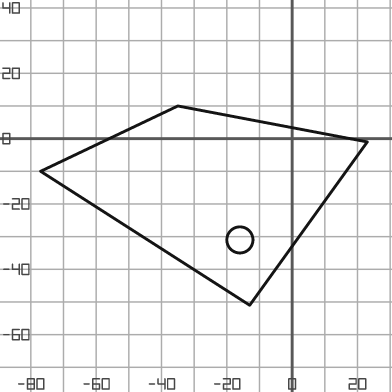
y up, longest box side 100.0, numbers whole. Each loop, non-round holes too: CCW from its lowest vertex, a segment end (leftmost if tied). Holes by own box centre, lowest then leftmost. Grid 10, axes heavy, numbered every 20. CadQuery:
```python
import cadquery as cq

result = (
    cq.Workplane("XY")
    .moveTo(-13.0, -51.0)
    .lineTo(23.0, -1.0)
    .lineTo(-35.0, 10.0)
    .lineTo(-77.0, -10.0)
    .close()
    .moveTo(-16.0, -31.0)
    .circle(4.0)
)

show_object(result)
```